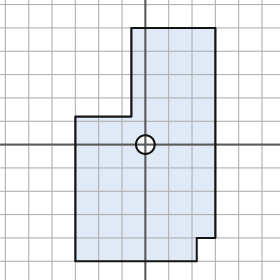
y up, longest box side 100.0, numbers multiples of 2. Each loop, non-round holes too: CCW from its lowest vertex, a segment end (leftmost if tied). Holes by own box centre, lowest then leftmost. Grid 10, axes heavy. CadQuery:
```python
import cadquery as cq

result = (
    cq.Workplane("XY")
    .moveTo(-30.0, -50.0)
    .lineTo(22.0, -50.0)
    .lineTo(22.0, -40.0)
    .lineTo(30.0, -40.0)
    .lineTo(30.0, 50.0)
    .lineTo(-6.0, 50.0)
    .lineTo(-6.0, 12.0)
    .lineTo(-30.0, 12.0)
    .close()
    .moveTo(0.0, 0.0)
    .circle(4.0)
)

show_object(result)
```